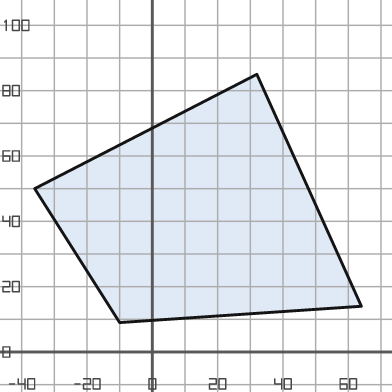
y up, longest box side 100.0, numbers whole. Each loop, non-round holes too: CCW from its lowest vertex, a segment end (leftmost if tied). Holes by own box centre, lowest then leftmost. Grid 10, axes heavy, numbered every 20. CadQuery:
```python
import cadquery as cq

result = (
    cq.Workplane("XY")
    .moveTo(-10.0, 9.0)
    .lineTo(64.0, 14.0)
    .lineTo(32.0, 85.0)
    .lineTo(-36.0, 50.0)
    .close()
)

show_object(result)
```